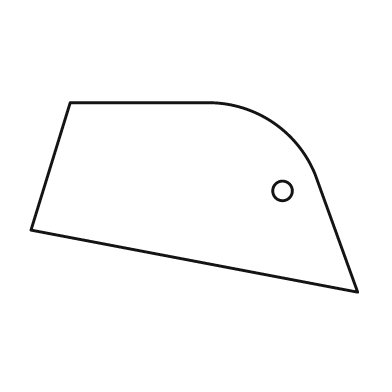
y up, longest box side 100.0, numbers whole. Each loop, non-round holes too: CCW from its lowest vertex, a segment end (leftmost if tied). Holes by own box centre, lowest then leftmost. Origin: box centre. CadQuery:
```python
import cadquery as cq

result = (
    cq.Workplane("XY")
    .moveTo(50.0, -29.0)
    .lineTo(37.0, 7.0)
    .threePointArc((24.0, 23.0), (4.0, 29.0))
    .lineTo(-38.0, 29.0)
    .lineTo(-50.0, -10.0)
    .close()
    .moveTo(27.0, 2.0)
    .circle(3.0)
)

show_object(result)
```